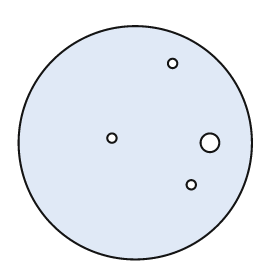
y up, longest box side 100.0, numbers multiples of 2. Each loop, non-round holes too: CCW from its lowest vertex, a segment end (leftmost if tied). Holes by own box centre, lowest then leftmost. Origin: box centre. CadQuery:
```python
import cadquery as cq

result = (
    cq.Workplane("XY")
    .moveTo(0.0, 0.0)
    .circle(50.0)
    .moveTo(24.0, -18.0)
    .circle(2.0)
    .moveTo(32.0, 0.0)
    .circle(4.0)
    .moveTo(-10.0, 2.0)
    .circle(2.0)
    .moveTo(16.0, 34.0)
    .circle(2.0)
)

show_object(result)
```